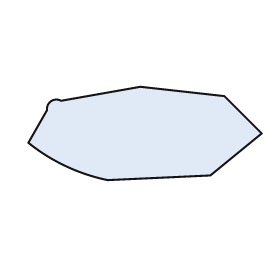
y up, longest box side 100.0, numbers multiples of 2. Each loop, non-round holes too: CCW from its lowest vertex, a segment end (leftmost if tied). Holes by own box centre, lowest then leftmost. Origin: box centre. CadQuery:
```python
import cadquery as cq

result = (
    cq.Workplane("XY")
    .moveTo(-16.0, -20.0)
    .lineTo(28.0, -18.0)
    .lineTo(50.0, 0.0)
    .lineTo(34.0, 16.0)
    .lineTo(-2.0, 20.0)
    .lineTo(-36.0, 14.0)
    .threePointArc((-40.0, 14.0), (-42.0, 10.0))
    .lineTo(-50.0, -4.0)
    .threePointArc((-34.0, -14.0), (-16.0, -20.0))
    .close()
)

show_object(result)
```